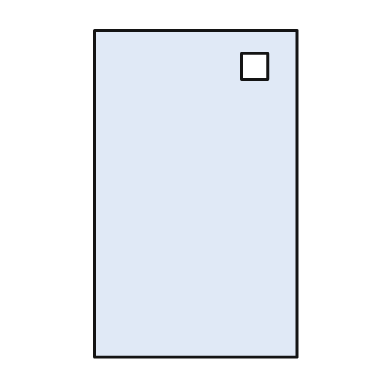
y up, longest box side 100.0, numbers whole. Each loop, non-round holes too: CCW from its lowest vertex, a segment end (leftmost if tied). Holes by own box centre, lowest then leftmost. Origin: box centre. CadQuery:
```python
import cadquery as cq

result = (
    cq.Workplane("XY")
    .moveTo(-31.0, -50.0)
    .lineTo(31.0, -50.0)
    .lineTo(31.0, 50.0)
    .lineTo(-31.0, 50.0)
    .close()
    .moveTo(14.0, 35.0)
    .lineTo(22.0, 35.0)
    .lineTo(22.0, 43.0)
    .lineTo(14.0, 43.0)
    .close()
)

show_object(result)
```